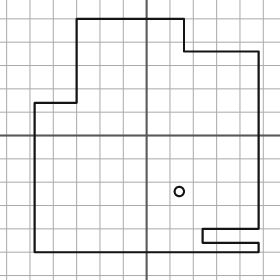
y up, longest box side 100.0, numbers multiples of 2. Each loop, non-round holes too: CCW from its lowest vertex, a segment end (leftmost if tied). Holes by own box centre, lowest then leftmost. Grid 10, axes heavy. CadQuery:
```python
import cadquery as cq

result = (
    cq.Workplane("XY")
    .moveTo(-48.0, -50.0)
    .lineTo(48.0, -50.0)
    .lineTo(48.0, -46.0)
    .lineTo(24.0, -46.0)
    .lineTo(24.0, -40.0)
    .lineTo(48.0, -40.0)
    .lineTo(48.0, 36.0)
    .lineTo(16.0, 36.0)
    .lineTo(16.0, 50.0)
    .lineTo(-30.0, 50.0)
    .lineTo(-30.0, 14.0)
    .lineTo(-48.0, 14.0)
    .close()
    .moveTo(14.0, -24.0)
    .circle(2.0)
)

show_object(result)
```